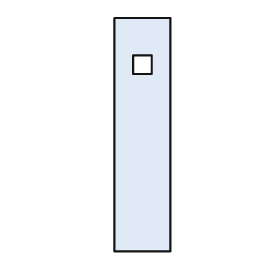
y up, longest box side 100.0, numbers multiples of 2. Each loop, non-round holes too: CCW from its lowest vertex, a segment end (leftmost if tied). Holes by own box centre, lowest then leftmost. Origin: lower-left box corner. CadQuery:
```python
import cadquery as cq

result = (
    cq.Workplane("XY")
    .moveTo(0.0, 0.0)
    .lineTo(24.0, 0.0)
    .lineTo(24.0, 100.0)
    .lineTo(0.0, 100.0)
    .close()
    .moveTo(8.0, 76.0)
    .lineTo(16.0, 76.0)
    .lineTo(16.0, 84.0)
    .lineTo(8.0, 84.0)
    .close()
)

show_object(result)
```